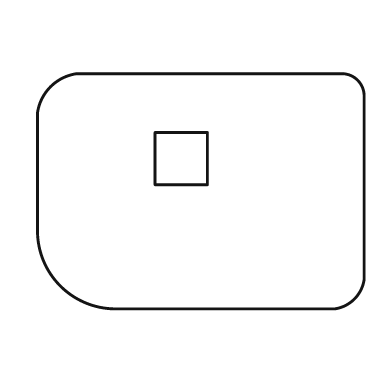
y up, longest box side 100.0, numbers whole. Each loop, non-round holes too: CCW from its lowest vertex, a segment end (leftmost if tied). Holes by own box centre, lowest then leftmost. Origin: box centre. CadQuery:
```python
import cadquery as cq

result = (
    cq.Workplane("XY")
    .moveTo(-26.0, -36.0)
    .lineTo(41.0, -36.0)
    .threePointArc((47.0, -33.0), (50.0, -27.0))
    .lineTo(50.0, 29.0)
    .threePointArc((48.0, 34.0), (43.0, 36.0))
    .lineTo(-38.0, 36.0)
    .threePointArc((-46.0, 32.0), (-50.0, 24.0))
    .lineTo(-50.0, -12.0)
    .threePointArc((-43.0, -29.0), (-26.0, -36.0))
    .close()
    .moveTo(-14.0, 2.0)
    .lineTo(2.0, 2.0)
    .lineTo(2.0, 18.0)
    .lineTo(-14.0, 18.0)
    .close()
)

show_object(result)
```